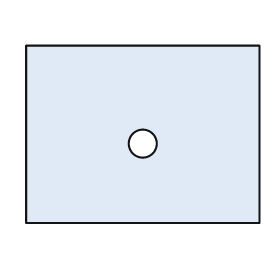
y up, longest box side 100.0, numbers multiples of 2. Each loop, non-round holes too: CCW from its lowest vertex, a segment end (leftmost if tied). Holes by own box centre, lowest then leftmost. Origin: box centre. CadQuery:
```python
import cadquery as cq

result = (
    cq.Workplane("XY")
    .moveTo(-50.0, -38.0)
    .lineTo(50.0, -38.0)
    .lineTo(50.0, 38.0)
    .lineTo(-50.0, 38.0)
    .close()
    .moveTo(0.0, -4.0)
    .circle(6.0)
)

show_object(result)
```